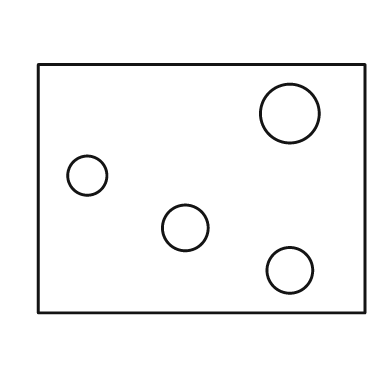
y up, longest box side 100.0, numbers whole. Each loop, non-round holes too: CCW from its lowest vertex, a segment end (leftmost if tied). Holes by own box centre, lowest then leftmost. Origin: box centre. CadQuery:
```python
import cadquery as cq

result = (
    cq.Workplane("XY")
    .moveTo(-50.0, -38.0)
    .lineTo(50.0, -38.0)
    .lineTo(50.0, 38.0)
    .lineTo(-50.0, 38.0)
    .close()
    .moveTo(27.0, -25.0)
    .circle(7.0)
    .moveTo(-5.0, -12.0)
    .circle(7.0)
    .moveTo(-35.0, 4.0)
    .circle(6.0)
    .moveTo(27.0, 23.0)
    .circle(9.0)
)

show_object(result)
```